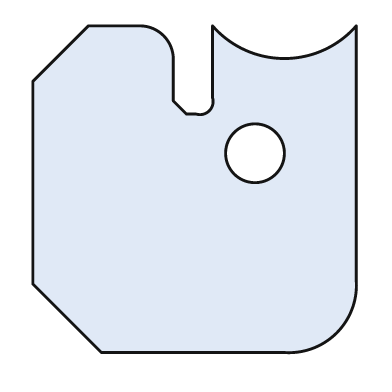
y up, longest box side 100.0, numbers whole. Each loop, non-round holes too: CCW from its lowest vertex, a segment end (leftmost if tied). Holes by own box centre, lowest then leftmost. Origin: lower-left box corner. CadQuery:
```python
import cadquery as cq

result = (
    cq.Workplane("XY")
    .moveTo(21.0, 0.0)
    .lineTo(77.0, 0.0)
    .threePointArc((93.0, 6.0), (99.0, 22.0))
    .lineTo(99.0, 100.0)
    .threePointArc((77.0, 90.0), (55.0, 100.0))
    .lineTo(55.0, 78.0)
    .threePointArc((54.0, 74.0), (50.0, 73.0))
    .lineTo(47.0, 73.0)
    .lineTo(43.0, 77.0)
    .lineTo(43.0, 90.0)
    .threePointArc((40.0, 97.0), (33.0, 100.0))
    .lineTo(17.0, 100.0)
    .lineTo(0.0, 83.0)
    .lineTo(0.0, 21.0)
    .close()
    .moveTo(68.0, 61.0)
    .circle(9.0)
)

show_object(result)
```